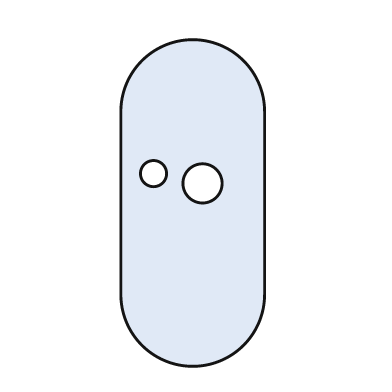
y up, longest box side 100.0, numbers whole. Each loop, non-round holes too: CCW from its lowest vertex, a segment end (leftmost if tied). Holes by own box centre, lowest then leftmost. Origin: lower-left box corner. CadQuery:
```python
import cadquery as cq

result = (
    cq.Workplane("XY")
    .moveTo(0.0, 22.0)
    .threePointArc((22.0, 0.0), (44.0, 22.0))
    .lineTo(44.0, 78.0)
    .threePointArc((22.0, 100.0), (0.0, 78.0))
    .close()
    .moveTo(25.0, 56.0)
    .circle(6.0)
    .moveTo(10.0, 59.0)
    .circle(4.0)
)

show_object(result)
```